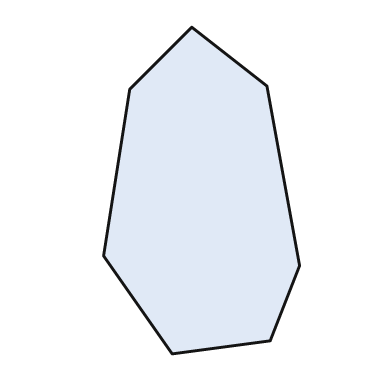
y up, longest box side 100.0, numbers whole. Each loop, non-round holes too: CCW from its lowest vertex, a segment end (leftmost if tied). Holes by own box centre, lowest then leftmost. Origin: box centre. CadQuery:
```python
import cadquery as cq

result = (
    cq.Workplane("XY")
    .moveTo(-9.0, -50.0)
    .lineTo(21.0, -46.0)
    .lineTo(30.0, -23.0)
    .lineTo(20.0, 32.0)
    .lineTo(-3.0, 50.0)
    .lineTo(-22.0, 31.0)
    .lineTo(-30.0, -20.0)
    .close()
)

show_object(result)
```